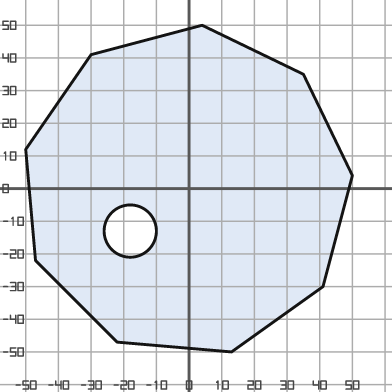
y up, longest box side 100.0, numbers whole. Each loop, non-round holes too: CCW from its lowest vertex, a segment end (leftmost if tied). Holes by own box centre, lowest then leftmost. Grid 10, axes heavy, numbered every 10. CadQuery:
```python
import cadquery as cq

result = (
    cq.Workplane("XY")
    .moveTo(13.0, -50.0)
    .lineTo(41.0, -30.0)
    .lineTo(50.0, 4.0)
    .lineTo(35.0, 35.0)
    .lineTo(4.0, 50.0)
    .lineTo(-30.0, 41.0)
    .lineTo(-50.0, 12.0)
    .lineTo(-47.0, -22.0)
    .lineTo(-22.0, -47.0)
    .close()
    .moveTo(-18.0, -13.0)
    .circle(8.0)
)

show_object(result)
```